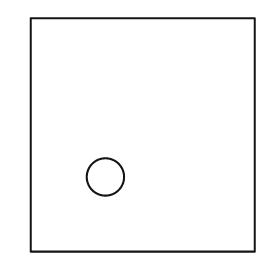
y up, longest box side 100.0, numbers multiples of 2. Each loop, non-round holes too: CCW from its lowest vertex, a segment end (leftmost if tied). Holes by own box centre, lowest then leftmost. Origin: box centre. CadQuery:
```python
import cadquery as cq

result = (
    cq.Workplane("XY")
    .moveTo(-48.0, -50.0)
    .lineTo(48.0, -50.0)
    .lineTo(48.0, 50.0)
    .lineTo(-48.0, 50.0)
    .close()
    .moveTo(-16.0, -18.0)
    .circle(8.0)
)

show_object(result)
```